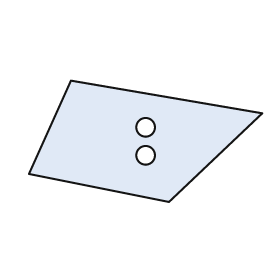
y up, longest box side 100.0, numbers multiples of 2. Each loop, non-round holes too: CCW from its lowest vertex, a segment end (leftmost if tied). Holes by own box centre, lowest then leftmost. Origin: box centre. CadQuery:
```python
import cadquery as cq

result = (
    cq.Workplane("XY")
    .moveTo(10.0, -26.0)
    .lineTo(50.0, 12.0)
    .lineTo(-32.0, 26.0)
    .lineTo(-50.0, -14.0)
    .close()
    .moveTo(0.0, -6.0)
    .circle(4.0)
    .moveTo(0.0, 6.0)
    .circle(4.0)
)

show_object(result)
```